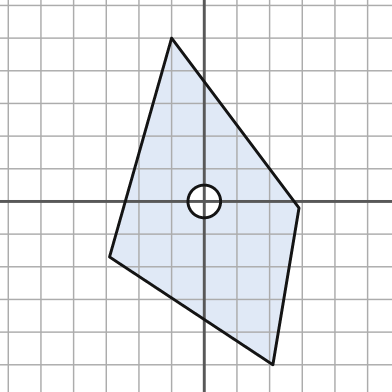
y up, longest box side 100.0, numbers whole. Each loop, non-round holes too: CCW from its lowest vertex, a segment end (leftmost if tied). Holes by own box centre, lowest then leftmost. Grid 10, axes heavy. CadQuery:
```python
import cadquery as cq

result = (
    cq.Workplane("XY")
    .moveTo(21.0, -50.0)
    .lineTo(29.0, -2.0)
    .lineTo(-10.0, 50.0)
    .lineTo(-29.0, -17.0)
    .close()
    .moveTo(0.0, 0.0)
    .circle(5.0)
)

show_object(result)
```